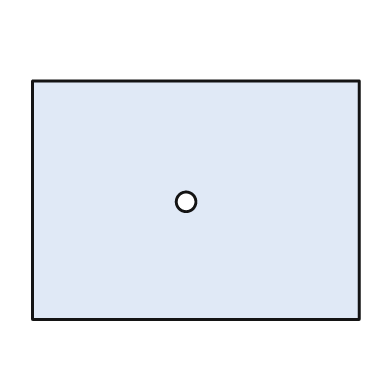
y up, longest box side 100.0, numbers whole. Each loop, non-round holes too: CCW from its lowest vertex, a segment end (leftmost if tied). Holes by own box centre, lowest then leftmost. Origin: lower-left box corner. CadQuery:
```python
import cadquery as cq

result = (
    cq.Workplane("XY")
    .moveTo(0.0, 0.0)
    .lineTo(100.0, 0.0)
    .lineTo(100.0, 73.0)
    .lineTo(0.0, 73.0)
    .close()
    .moveTo(47.0, 36.0)
    .circle(3.0)
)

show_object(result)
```